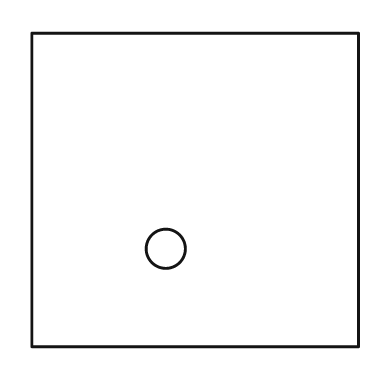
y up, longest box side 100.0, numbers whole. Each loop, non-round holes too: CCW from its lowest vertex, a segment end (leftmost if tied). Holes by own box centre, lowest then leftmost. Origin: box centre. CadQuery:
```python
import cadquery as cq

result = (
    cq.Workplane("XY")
    .moveTo(-50.0, -48.0)
    .lineTo(50.0, -48.0)
    .lineTo(50.0, 48.0)
    .lineTo(-50.0, 48.0)
    .close()
    .moveTo(-9.0, -18.0)
    .circle(6.0)
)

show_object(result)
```